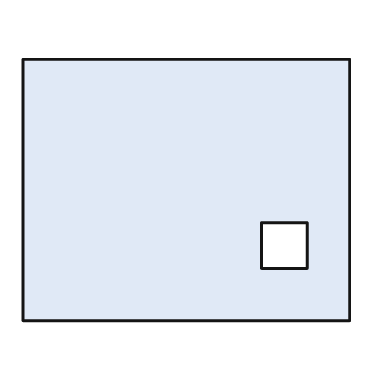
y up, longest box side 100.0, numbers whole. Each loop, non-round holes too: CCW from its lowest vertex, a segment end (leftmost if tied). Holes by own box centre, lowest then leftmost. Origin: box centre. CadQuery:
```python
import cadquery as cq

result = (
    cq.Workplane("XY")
    .moveTo(-50.0, -40.0)
    .lineTo(50.0, -40.0)
    .lineTo(50.0, 40.0)
    .lineTo(-50.0, 40.0)
    .close()
    .moveTo(23.0, -24.0)
    .lineTo(37.0, -24.0)
    .lineTo(37.0, -10.0)
    .lineTo(23.0, -10.0)
    .close()
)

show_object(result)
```